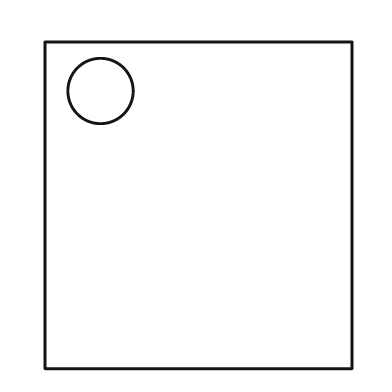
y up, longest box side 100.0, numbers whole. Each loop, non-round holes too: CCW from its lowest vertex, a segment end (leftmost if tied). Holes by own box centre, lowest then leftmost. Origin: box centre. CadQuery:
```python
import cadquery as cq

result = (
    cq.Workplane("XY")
    .moveTo(-47.0, -50.0)
    .lineTo(47.0, -50.0)
    .lineTo(47.0, 50.0)
    .lineTo(-47.0, 50.0)
    .close()
    .moveTo(-30.0, 35.0)
    .circle(10.0)
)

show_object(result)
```